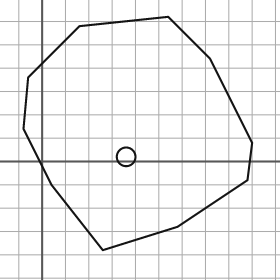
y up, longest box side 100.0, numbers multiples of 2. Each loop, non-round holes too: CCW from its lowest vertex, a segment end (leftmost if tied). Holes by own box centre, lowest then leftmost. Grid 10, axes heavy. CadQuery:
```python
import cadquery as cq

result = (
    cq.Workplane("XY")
    .moveTo(26.0, -38.0)
    .lineTo(58.0, -28.0)
    .lineTo(88.0, -8.0)
    .lineTo(90.0, 8.0)
    .lineTo(72.0, 44.0)
    .lineTo(54.0, 62.0)
    .lineTo(16.0, 58.0)
    .lineTo(-6.0, 36.0)
    .lineTo(-8.0, 14.0)
    .lineTo(4.0, -10.0)
    .close()
    .moveTo(36.0, 2.0)
    .circle(4.0)
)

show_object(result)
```